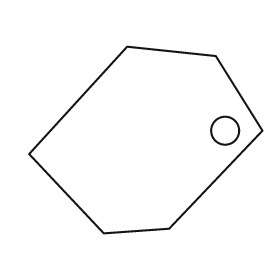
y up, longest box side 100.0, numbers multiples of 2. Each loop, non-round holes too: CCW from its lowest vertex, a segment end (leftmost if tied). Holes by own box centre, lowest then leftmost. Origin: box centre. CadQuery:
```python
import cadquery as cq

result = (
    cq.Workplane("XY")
    .moveTo(-18.0, -40.0)
    .lineTo(10.0, -38.0)
    .lineTo(50.0, 4.0)
    .lineTo(30.0, 36.0)
    .lineTo(-8.0, 40.0)
    .lineTo(-50.0, -6.0)
    .close()
    .moveTo(34.0, 4.0)
    .circle(6.0)
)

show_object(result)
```